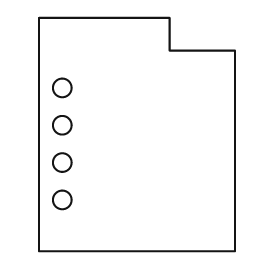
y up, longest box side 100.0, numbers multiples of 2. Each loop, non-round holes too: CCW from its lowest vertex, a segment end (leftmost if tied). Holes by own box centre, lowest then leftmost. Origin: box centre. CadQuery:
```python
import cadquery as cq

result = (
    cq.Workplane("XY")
    .moveTo(-42.0, -50.0)
    .lineTo(42.0, -50.0)
    .lineTo(42.0, 36.0)
    .lineTo(14.0, 36.0)
    .lineTo(14.0, 50.0)
    .lineTo(-42.0, 50.0)
    .close()
    .moveTo(-32.0, -28.0)
    .circle(4.0)
    .moveTo(-32.0, -12.0)
    .circle(4.0)
    .moveTo(-32.0, 4.0)
    .circle(4.0)
    .moveTo(-32.0, 20.0)
    .circle(4.0)
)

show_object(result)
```